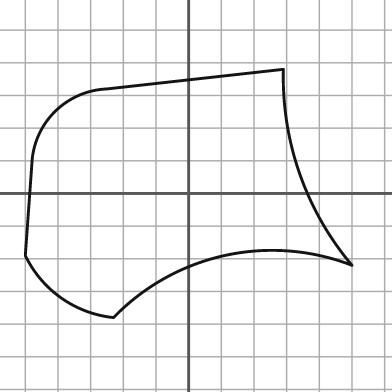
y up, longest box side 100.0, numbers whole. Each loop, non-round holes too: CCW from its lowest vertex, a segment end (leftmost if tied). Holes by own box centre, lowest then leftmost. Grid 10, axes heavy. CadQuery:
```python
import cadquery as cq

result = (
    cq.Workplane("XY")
    .moveTo(-23.0, -38.0)
    .threePointArc((11.0, -19.0), (50.0, -22.0))
    .threePointArc((34.0, 6.0), (29.0, 38.0))
    .lineTo(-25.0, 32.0)
    .threePointArc((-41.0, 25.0), (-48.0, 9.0))
    .lineTo(-50.0, -19.0)
    .threePointArc((-39.0, -32.0), (-23.0, -38.0))
    .close()
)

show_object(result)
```